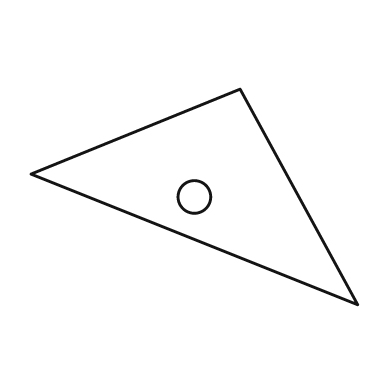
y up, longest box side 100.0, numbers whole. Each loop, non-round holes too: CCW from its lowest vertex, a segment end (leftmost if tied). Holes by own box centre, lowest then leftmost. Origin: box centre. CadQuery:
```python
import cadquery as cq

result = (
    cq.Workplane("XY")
    .moveTo(50.0, -33.0)
    .lineTo(14.0, 33.0)
    .lineTo(-50.0, 7.0)
    .close()
    .moveTo(0.0, 0.0)
    .circle(5.0)
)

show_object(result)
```